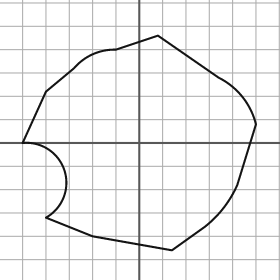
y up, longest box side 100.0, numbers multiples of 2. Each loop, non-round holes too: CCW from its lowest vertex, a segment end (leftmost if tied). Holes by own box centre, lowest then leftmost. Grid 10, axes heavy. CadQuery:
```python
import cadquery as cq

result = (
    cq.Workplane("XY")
    .moveTo(14.0, -46.0)
    .lineTo(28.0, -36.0)
    .threePointArc((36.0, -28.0), (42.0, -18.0))
    .lineTo(50.0, 8.0)
    .threePointArc((44.0, 20.0), (34.0, 28.0))
    .lineTo(8.0, 46.0)
    .lineTo(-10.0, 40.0)
    .threePointArc((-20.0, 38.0), (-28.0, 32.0))
    .lineTo(-40.0, 22.0)
    .lineTo(-50.0, 0.0)
    .threePointArc((-32.0, -12.0), (-40.0, -32.0))
    .lineTo(-20.0, -40.0)
    .close()
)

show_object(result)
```